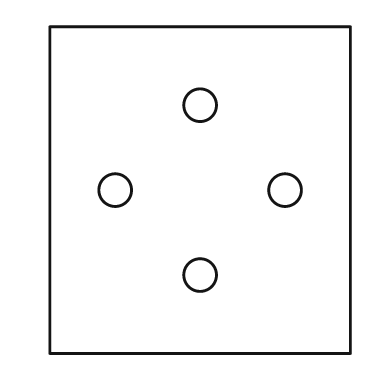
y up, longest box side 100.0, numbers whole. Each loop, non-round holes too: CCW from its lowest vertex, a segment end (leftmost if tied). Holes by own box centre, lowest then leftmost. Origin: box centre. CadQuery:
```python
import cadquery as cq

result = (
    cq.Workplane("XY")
    .moveTo(-46.0, -50.0)
    .lineTo(46.0, -50.0)
    .lineTo(46.0, 50.0)
    .lineTo(-46.0, 50.0)
    .close()
    .moveTo(0.0, -26.0)
    .circle(5.0)
    .moveTo(-26.0, 0.0)
    .circle(5.0)
    .moveTo(26.0, 0.0)
    .circle(5.0)
    .moveTo(0.0, 26.0)
    .circle(5.0)
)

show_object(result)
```